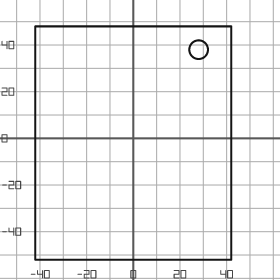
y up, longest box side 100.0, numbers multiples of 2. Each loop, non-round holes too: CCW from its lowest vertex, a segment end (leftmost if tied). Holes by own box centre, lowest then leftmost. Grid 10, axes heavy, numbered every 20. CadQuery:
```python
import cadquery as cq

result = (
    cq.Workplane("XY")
    .moveTo(-42.0, -52.0)
    .lineTo(42.0, -52.0)
    .lineTo(42.0, 48.0)
    .lineTo(-42.0, 48.0)
    .close()
    .moveTo(28.0, 38.0)
    .circle(4.0)
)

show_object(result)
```